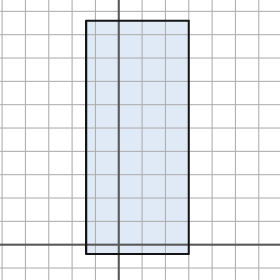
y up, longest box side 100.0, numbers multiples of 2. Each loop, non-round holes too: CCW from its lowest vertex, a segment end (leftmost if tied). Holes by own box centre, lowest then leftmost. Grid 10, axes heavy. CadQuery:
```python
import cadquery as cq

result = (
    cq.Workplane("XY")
    .moveTo(-14.0, -4.0)
    .lineTo(30.0, -4.0)
    .lineTo(30.0, 96.0)
    .lineTo(-14.0, 96.0)
    .close()
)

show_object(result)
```